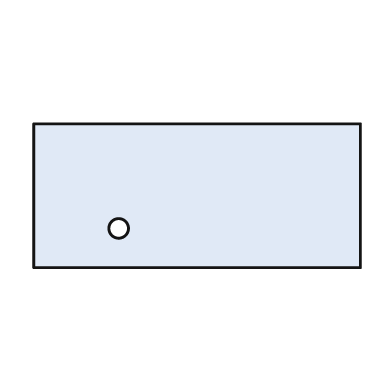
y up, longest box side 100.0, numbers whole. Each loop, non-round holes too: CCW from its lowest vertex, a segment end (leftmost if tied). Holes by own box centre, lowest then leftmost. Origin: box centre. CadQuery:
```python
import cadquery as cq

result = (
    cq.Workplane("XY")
    .moveTo(-50.0, -22.0)
    .lineTo(50.0, -22.0)
    .lineTo(50.0, 22.0)
    .lineTo(-50.0, 22.0)
    .close()
    .moveTo(-24.0, -10.0)
    .circle(3.0)
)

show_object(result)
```